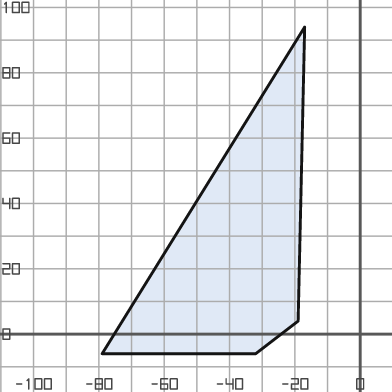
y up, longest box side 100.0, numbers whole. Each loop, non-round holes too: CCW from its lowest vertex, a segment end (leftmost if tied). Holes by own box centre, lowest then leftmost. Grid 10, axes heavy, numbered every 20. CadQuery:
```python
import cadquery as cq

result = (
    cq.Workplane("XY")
    .moveTo(-79.0, -6.0)
    .lineTo(-32.0, -6.0)
    .lineTo(-19.0, 4.0)
    .lineTo(-17.0, 94.0)
    .close()
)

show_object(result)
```